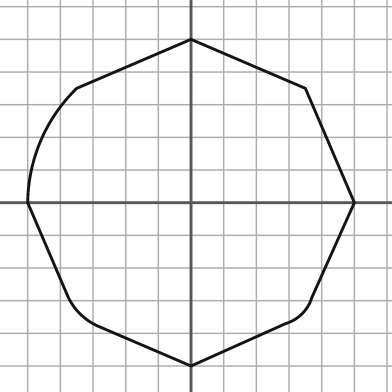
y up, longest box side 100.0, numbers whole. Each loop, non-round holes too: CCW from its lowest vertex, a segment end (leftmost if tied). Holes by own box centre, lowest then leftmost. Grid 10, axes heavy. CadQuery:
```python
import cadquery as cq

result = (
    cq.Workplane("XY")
    .moveTo(0.0, -50.0)
    .lineTo(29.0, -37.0)
    .threePointArc((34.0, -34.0), (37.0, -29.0))
    .lineTo(50.0, 0.0)
    .lineTo(35.0, 35.0)
    .lineTo(0.0, 50.0)
    .lineTo(-35.0, 35.0)
    .threePointArc((-46.0, 19.0), (-50.0, 0.0))
    .lineTo(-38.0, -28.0)
    .threePointArc((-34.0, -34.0), (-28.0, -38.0))
    .close()
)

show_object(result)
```